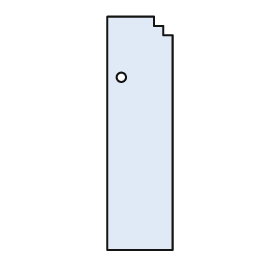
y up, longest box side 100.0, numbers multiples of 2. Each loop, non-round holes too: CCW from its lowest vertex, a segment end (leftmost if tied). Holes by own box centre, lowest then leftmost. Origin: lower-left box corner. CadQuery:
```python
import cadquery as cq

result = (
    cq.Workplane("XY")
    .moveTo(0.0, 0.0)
    .lineTo(28.0, 0.0)
    .lineTo(28.0, 92.0)
    .lineTo(24.0, 92.0)
    .lineTo(24.0, 96.0)
    .lineTo(20.0, 96.0)
    .lineTo(20.0, 100.0)
    .lineTo(0.0, 100.0)
    .close()
    .moveTo(6.0, 74.0)
    .circle(2.0)
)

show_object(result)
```